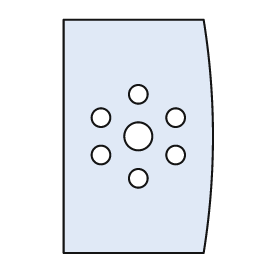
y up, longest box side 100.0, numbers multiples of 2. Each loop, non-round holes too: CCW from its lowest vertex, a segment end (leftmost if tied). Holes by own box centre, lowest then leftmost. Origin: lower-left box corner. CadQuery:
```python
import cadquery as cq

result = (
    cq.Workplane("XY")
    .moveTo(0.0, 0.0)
    .lineTo(60.0, 0.0)
    .threePointArc((64.0, 50.0), (60.0, 100.0))
    .lineTo(0.0, 100.0)
    .close()
    .moveTo(32.0, 32.0)
    .circle(4.0)
    .moveTo(16.0, 42.0)
    .circle(4.0)
    .moveTo(48.0, 42.0)
    .circle(4.0)
    .moveTo(32.0, 50.0)
    .circle(6.0)
    .moveTo(16.0, 58.0)
    .circle(4.0)
    .moveTo(48.0, 58.0)
    .circle(4.0)
    .moveTo(32.0, 68.0)
    .circle(4.0)
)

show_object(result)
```